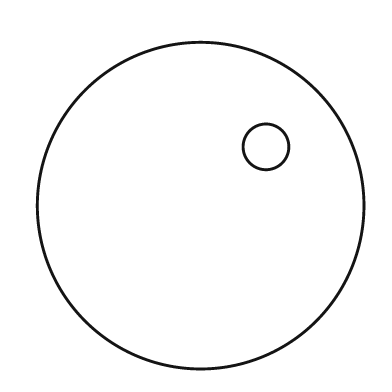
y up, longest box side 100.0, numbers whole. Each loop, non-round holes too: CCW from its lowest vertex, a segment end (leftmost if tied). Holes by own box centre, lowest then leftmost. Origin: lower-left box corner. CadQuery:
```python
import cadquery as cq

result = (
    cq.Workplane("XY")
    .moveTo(50.0, 50.0)
    .circle(50.0)
    .moveTo(70.0, 68.0)
    .circle(7.0)
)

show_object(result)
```